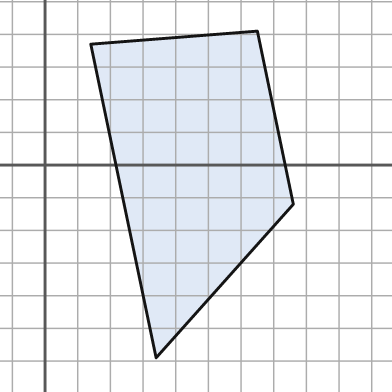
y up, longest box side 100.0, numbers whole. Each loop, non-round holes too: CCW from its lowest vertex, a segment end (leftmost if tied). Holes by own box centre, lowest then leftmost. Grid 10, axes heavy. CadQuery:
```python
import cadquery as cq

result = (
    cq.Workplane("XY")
    .moveTo(34.0, -59.0)
    .lineTo(76.0, -12.0)
    .lineTo(65.0, 41.0)
    .lineTo(14.0, 37.0)
    .close()
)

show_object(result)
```